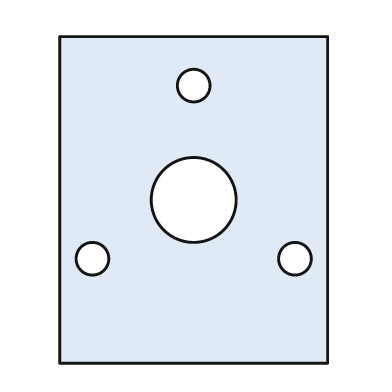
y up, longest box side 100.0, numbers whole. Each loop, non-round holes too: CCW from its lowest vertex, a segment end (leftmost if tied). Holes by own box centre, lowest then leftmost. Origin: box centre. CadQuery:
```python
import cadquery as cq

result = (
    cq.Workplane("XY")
    .moveTo(-41.0, -50.0)
    .lineTo(41.0, -50.0)
    .lineTo(41.0, 50.0)
    .lineTo(-41.0, 50.0)
    .close()
    .moveTo(-31.0, -18.0)
    .circle(5.0)
    .moveTo(31.0, -18.0)
    .circle(5.0)
    .moveTo(0.0, 0.0)
    .circle(13.0)
    .moveTo(0.0, 35.0)
    .circle(5.0)
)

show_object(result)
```